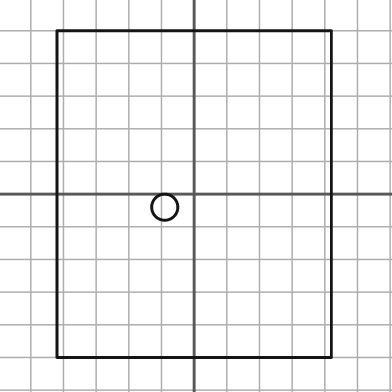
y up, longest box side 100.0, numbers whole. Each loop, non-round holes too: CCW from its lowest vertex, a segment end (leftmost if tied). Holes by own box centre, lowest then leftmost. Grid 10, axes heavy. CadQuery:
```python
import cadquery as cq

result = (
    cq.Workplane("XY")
    .moveTo(-42.0, -50.0)
    .lineTo(42.0, -50.0)
    .lineTo(42.0, 50.0)
    .lineTo(-42.0, 50.0)
    .close()
    .moveTo(-9.0, -4.0)
    .circle(4.0)
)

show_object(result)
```